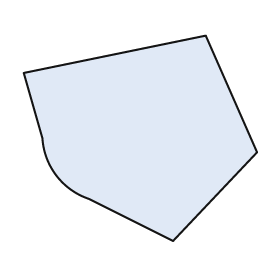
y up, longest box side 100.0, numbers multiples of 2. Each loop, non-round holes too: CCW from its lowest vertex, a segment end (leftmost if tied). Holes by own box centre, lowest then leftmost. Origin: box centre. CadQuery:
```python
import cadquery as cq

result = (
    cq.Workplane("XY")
    .moveTo(14.0, -44.0)
    .lineTo(50.0, -6.0)
    .lineTo(28.0, 44.0)
    .lineTo(-50.0, 28.0)
    .lineTo(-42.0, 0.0)
    .threePointArc((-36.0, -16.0), (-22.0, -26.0))
    .close()
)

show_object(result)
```